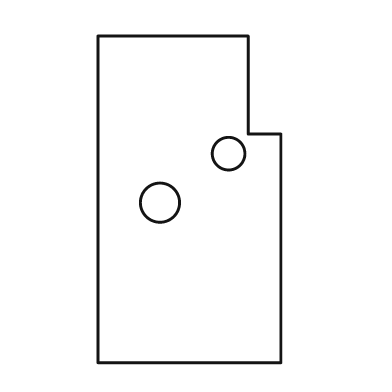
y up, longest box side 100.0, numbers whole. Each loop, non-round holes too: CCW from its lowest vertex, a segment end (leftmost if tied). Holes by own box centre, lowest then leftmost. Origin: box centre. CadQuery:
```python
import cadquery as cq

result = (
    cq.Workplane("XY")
    .moveTo(-28.0, -50.0)
    .lineTo(28.0, -50.0)
    .lineTo(28.0, 20.0)
    .lineTo(18.0, 20.0)
    .lineTo(18.0, 50.0)
    .lineTo(-28.0, 50.0)
    .close()
    .moveTo(-9.0, -1.0)
    .circle(6.0)
    .moveTo(12.0, 14.0)
    .circle(5.0)
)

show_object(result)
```